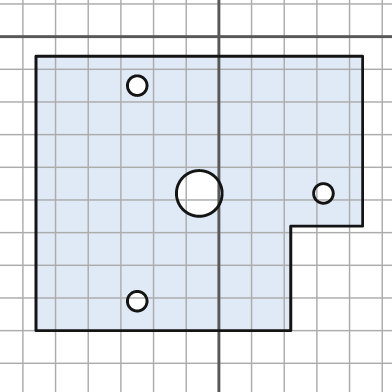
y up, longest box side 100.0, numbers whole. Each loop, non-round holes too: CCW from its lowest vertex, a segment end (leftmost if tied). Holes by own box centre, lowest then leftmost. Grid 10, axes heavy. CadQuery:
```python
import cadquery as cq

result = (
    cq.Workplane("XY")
    .moveTo(-56.0, -90.0)
    .lineTo(22.0, -90.0)
    .lineTo(22.0, -58.0)
    .lineTo(44.0, -58.0)
    .lineTo(44.0, -6.0)
    .lineTo(-56.0, -6.0)
    .close()
    .moveTo(-25.0, -81.0)
    .circle(3.0)
    .moveTo(-6.0, -48.0)
    .circle(7.0)
    .moveTo(32.0, -48.0)
    .circle(3.0)
    .moveTo(-25.0, -15.0)
    .circle(3.0)
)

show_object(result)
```